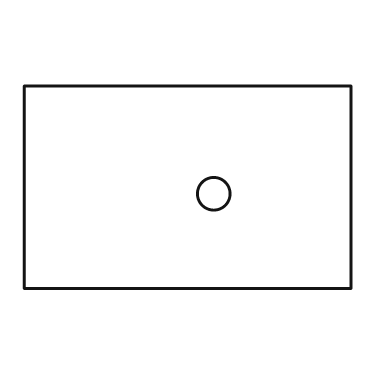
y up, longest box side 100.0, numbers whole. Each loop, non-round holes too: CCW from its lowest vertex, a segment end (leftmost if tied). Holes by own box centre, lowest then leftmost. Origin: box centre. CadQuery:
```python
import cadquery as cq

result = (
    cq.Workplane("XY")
    .moveTo(-50.0, -31.0)
    .lineTo(50.0, -31.0)
    .lineTo(50.0, 31.0)
    .lineTo(-50.0, 31.0)
    .close()
    .moveTo(8.0, -2.0)
    .circle(5.0)
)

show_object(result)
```